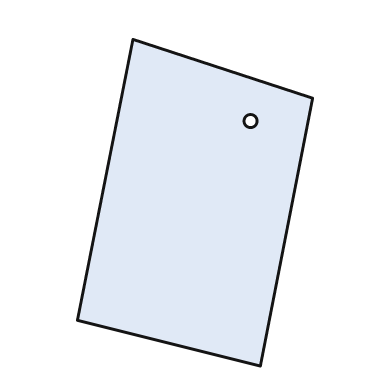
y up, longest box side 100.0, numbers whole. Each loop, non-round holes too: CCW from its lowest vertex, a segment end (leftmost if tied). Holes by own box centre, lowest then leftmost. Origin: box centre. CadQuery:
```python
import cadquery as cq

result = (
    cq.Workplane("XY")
    .moveTo(20.0, -50.0)
    .lineTo(36.0, 32.0)
    .lineTo(-19.0, 50.0)
    .lineTo(-36.0, -36.0)
    .close()
    .moveTo(17.0, 25.0)
    .circle(2.0)
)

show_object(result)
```